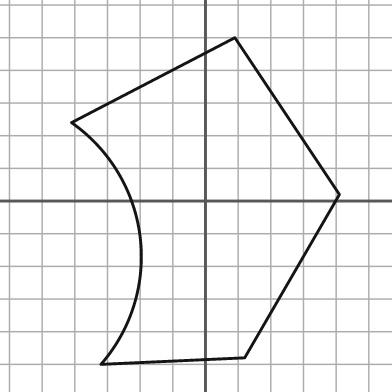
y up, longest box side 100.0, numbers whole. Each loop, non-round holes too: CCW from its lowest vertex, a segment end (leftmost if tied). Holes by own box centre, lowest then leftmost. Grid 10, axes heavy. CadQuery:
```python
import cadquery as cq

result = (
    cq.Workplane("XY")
    .moveTo(-32.0, -50.0)
    .lineTo(12.0, -48.0)
    .lineTo(41.0, 2.0)
    .lineTo(9.0, 50.0)
    .lineTo(-41.0, 24.0)
    .threePointArc((-20.0, -11.0), (-32.0, -50.0))
    .close()
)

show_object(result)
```